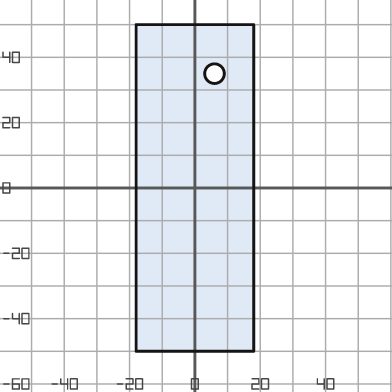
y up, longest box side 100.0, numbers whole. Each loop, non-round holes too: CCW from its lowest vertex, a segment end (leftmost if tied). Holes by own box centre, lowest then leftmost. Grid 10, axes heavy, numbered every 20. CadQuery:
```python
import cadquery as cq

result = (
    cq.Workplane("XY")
    .moveTo(-18.0, -50.0)
    .lineTo(18.0, -50.0)
    .lineTo(18.0, 50.0)
    .lineTo(-18.0, 50.0)
    .close()
    .moveTo(6.0, 35.0)
    .circle(3.0)
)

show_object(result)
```